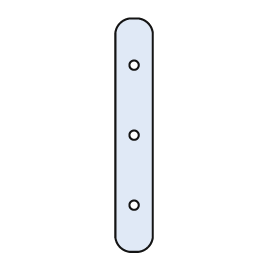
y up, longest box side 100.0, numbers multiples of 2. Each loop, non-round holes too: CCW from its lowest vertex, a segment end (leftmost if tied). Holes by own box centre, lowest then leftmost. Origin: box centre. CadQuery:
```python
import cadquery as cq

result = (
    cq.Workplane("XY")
    .moveTo(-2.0, -50.0)
    .lineTo(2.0, -50.0)
    .threePointArc((6.0, -48.0), (8.0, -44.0))
    .lineTo(8.0, 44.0)
    .threePointArc((6.0, 48.0), (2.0, 50.0))
    .lineTo(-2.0, 50.0)
    .threePointArc((-6.0, 48.0), (-8.0, 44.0))
    .lineTo(-8.0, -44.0)
    .threePointArc((-6.0, -48.0), (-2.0, -50.0))
    .close()
    .moveTo(0.0, -30.0)
    .circle(2.0)
    .moveTo(0.0, 0.0)
    .circle(2.0)
    .moveTo(0.0, 30.0)
    .circle(2.0)
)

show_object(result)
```